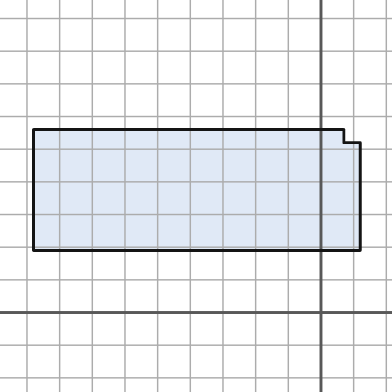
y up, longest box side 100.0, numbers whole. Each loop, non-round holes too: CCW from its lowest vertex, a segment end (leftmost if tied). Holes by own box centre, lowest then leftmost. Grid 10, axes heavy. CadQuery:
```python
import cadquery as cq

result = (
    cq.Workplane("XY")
    .moveTo(-88.0, 19.0)
    .lineTo(12.0, 19.0)
    .lineTo(12.0, 52.0)
    .lineTo(7.0, 52.0)
    .lineTo(7.0, 56.0)
    .lineTo(-88.0, 56.0)
    .close()
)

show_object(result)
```